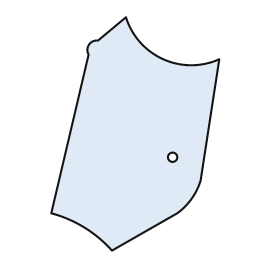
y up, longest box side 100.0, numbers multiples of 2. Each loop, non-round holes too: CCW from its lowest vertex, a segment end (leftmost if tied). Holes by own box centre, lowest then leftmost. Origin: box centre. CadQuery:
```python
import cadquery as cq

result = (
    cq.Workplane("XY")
    .moveTo(-10.0, -50.0)
    .lineTo(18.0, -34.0)
    .threePointArc((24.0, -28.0), (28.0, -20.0))
    .lineTo(36.0, 32.0)
    .threePointArc((12.0, 32.0), (-4.0, 50.0))
    .lineTo(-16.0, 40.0)
    .threePointArc((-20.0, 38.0), (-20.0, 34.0))
    .lineTo(-36.0, -34.0)
    .threePointArc((-22.0, -40.0), (-10.0, -50.0))
    .close()
    .moveTo(16.0, -10.0)
    .circle(2.0)
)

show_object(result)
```